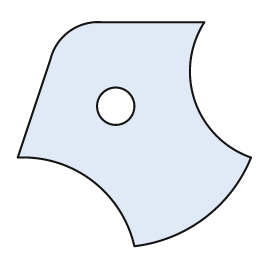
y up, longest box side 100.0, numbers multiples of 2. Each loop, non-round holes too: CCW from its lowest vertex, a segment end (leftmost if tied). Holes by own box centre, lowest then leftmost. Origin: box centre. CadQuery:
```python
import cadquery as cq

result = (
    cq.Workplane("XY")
    .moveTo(0.0, -48.0)
    .threePointArc((30.0, -36.0), (50.0, -10.0))
    .threePointArc((26.0, 14.0), (30.0, 48.0))
    .lineTo(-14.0, 48.0)
    .threePointArc((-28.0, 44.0), (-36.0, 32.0))
    .lineTo(-50.0, -10.0)
    .threePointArc((-18.0, -20.0), (0.0, -48.0))
    .close()
    .moveTo(-8.0, 12.0)
    .circle(8.0)
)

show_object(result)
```